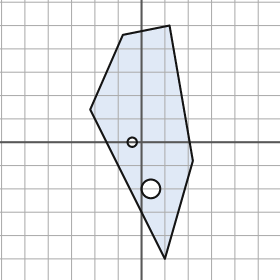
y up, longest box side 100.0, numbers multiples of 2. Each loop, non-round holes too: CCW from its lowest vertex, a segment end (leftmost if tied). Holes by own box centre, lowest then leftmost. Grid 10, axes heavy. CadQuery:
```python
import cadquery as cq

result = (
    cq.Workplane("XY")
    .moveTo(10.0, -50.0)
    .lineTo(22.0, -8.0)
    .lineTo(12.0, 50.0)
    .lineTo(-8.0, 46.0)
    .lineTo(-22.0, 14.0)
    .close()
    .moveTo(4.0, -20.0)
    .circle(4.0)
    .moveTo(-4.0, 0.0)
    .circle(2.0)
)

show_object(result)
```